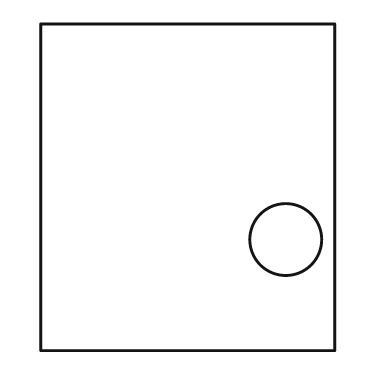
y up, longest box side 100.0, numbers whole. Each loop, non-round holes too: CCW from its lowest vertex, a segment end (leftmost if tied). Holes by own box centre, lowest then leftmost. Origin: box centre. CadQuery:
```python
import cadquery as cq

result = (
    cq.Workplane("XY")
    .moveTo(-45.0, -50.0)
    .lineTo(45.0, -50.0)
    .lineTo(45.0, 50.0)
    .lineTo(-45.0, 50.0)
    .close()
    .moveTo(30.0, -16.0)
    .circle(11.0)
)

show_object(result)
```